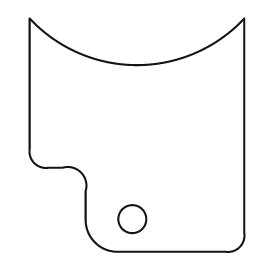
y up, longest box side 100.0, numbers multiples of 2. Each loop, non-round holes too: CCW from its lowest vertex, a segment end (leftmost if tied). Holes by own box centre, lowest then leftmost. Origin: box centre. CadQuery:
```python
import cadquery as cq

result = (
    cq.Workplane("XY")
    .moveTo(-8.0, -50.0)
    .lineTo(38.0, -50.0)
    .threePointArc((44.0, -48.0), (46.0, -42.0))
    .lineTo(46.0, 50.0)
    .threePointArc((0.0, 30.0), (-46.0, 50.0))
    .lineTo(-46.0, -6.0)
    .threePointArc((-44.0, -12.0), (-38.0, -14.0))
    .lineTo(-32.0, -14.0)
    .threePointArc((-24.0, -16.0), (-22.0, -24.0))
    .lineTo(-22.0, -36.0)
    .threePointArc((-18.0, -46.0), (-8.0, -50.0))
    .close()
    .moveTo(-2.0, -36.0)
    .circle(6.0)
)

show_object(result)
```